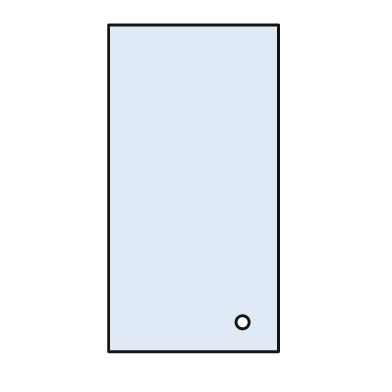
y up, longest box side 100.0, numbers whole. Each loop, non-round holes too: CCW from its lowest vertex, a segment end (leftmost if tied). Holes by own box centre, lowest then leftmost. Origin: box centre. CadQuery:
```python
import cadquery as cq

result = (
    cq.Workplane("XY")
    .moveTo(-26.0, -50.0)
    .lineTo(26.0, -50.0)
    .lineTo(26.0, 50.0)
    .lineTo(-26.0, 50.0)
    .close()
    .moveTo(15.0, -41.0)
    .circle(2.0)
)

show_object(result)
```